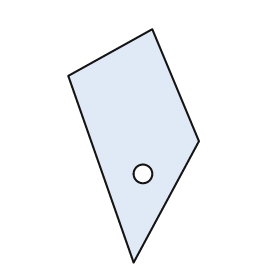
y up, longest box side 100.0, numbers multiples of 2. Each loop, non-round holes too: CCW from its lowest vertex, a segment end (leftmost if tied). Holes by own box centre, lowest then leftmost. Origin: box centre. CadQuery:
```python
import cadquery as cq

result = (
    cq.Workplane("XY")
    .moveTo(0.0, -50.0)
    .lineTo(28.0, 2.0)
    .lineTo(8.0, 50.0)
    .lineTo(-28.0, 30.0)
    .close()
    .moveTo(4.0, -12.0)
    .circle(4.0)
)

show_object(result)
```